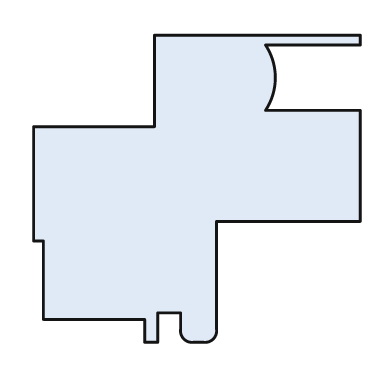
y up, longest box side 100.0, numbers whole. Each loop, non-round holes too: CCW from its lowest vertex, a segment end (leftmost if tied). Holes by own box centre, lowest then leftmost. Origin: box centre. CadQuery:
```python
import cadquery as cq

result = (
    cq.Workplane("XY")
    .moveTo(-16.0, -47.0)
    .lineTo(-12.0, -47.0)
    .lineTo(-12.0, -38.0)
    .lineTo(-5.0, -38.0)
    .lineTo(-5.0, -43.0)
    .threePointArc((-4.0, -46.0), (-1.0, -47.0))
    .lineTo(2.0, -47.0)
    .threePointArc((5.0, -46.0), (6.0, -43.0))
    .lineTo(6.0, -10.0)
    .lineTo(50.0, -10.0)
    .lineTo(50.0, 24.0)
    .lineTo(21.0, 24.0)
    .threePointArc((24.0, 34.0), (21.0, 44.0))
    .lineTo(50.0, 44.0)
    .lineTo(50.0, 47.0)
    .lineTo(-13.0, 47.0)
    .lineTo(-13.0, 19.0)
    .lineTo(-50.0, 19.0)
    .lineTo(-50.0, -16.0)
    .lineTo(-47.0, -16.0)
    .lineTo(-47.0, -40.0)
    .lineTo(-16.0, -40.0)
    .close()
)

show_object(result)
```